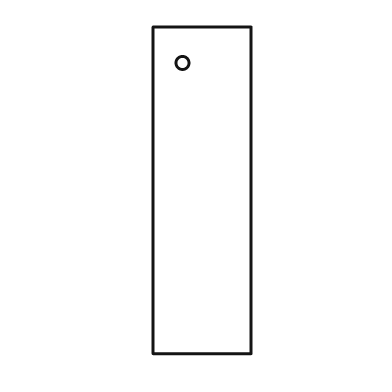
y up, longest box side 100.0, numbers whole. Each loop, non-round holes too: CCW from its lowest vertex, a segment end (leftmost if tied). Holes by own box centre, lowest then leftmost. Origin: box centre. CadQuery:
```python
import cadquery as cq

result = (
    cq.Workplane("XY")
    .moveTo(-15.0, -50.0)
    .lineTo(15.0, -50.0)
    .lineTo(15.0, 50.0)
    .lineTo(-15.0, 50.0)
    .close()
    .moveTo(-6.0, 39.0)
    .circle(2.0)
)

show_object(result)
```